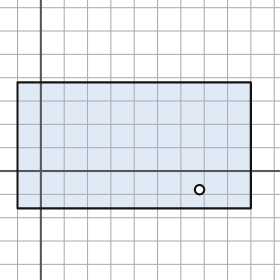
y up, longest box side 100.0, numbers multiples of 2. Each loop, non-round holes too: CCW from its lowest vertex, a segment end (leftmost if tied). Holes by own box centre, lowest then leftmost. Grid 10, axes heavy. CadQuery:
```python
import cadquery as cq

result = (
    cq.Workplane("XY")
    .moveTo(-10.0, -16.0)
    .lineTo(90.0, -16.0)
    .lineTo(90.0, 38.0)
    .lineTo(-10.0, 38.0)
    .close()
    .moveTo(68.0, -8.0)
    .circle(2.0)
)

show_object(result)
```